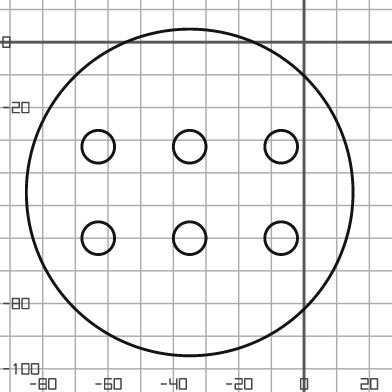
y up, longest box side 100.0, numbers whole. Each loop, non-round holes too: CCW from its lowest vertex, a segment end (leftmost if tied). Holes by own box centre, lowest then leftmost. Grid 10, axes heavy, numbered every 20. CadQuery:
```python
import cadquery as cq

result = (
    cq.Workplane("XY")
    .moveTo(-35.0, -46.0)
    .circle(50.0)
    .moveTo(-63.0, -60.0)
    .circle(5.0)
    .moveTo(-35.0, -60.0)
    .circle(5.0)
    .moveTo(-7.0, -60.0)
    .circle(5.0)
    .moveTo(-63.0, -32.0)
    .circle(5.0)
    .moveTo(-35.0, -32.0)
    .circle(5.0)
    .moveTo(-7.0, -32.0)
    .circle(5.0)
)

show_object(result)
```